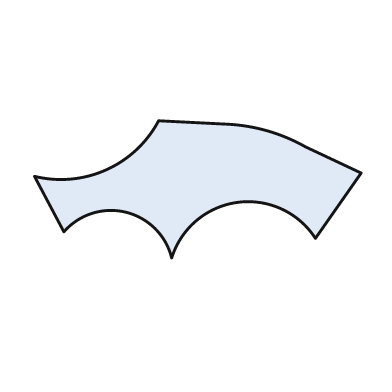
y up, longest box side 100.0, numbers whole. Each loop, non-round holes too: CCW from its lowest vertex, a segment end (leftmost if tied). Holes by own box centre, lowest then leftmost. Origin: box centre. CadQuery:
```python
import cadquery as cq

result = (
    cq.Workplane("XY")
    .moveTo(-8.0, -21.0)
    .threePointArc((12.0, -4.0), (36.0, -15.0))
    .lineTo(50.0, 5.0)
    .lineTo(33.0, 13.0)
    .threePointArc((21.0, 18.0), (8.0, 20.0))
    .lineTo(-12.0, 21.0)
    .threePointArc((-28.0, 6.0), (-50.0, 4.0))
    .lineTo(-41.0, -13.0)
    .threePointArc((-22.0, -7.0), (-8.0, -21.0))
    .close()
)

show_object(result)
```